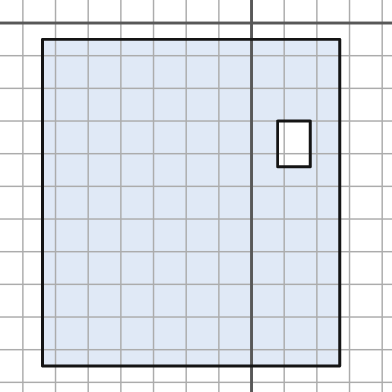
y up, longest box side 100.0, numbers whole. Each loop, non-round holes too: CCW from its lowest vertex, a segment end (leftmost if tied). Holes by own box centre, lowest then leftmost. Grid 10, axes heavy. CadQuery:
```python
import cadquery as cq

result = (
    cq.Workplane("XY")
    .moveTo(-64.0, -105.0)
    .lineTo(27.0, -105.0)
    .lineTo(27.0, -5.0)
    .lineTo(-64.0, -5.0)
    .close()
    .moveTo(8.0, -44.0)
    .lineTo(18.0, -44.0)
    .lineTo(18.0, -30.0)
    .lineTo(8.0, -30.0)
    .close()
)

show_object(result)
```